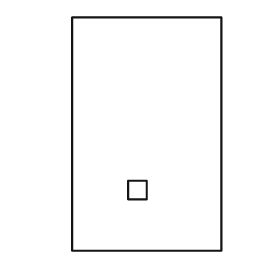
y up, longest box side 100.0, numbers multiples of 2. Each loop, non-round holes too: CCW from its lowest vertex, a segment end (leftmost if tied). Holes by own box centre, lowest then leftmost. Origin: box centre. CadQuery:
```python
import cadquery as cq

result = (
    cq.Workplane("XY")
    .moveTo(-32.0, -50.0)
    .lineTo(32.0, -50.0)
    .lineTo(32.0, 50.0)
    .lineTo(-32.0, 50.0)
    .close()
    .moveTo(-8.0, -28.0)
    .lineTo(0.0, -28.0)
    .lineTo(0.0, -20.0)
    .lineTo(-8.0, -20.0)
    .close()
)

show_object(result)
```